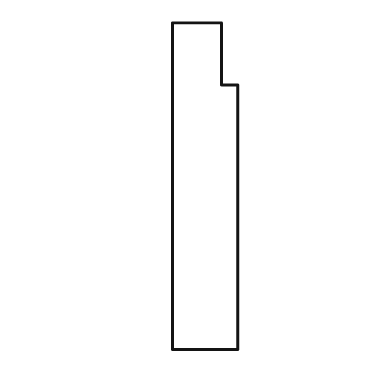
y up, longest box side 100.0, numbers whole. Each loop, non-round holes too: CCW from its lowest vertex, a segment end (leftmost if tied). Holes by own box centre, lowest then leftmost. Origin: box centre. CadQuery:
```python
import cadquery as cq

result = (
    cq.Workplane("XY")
    .moveTo(-10.0, -50.0)
    .lineTo(10.0, -50.0)
    .lineTo(10.0, 31.0)
    .lineTo(5.0, 31.0)
    .lineTo(5.0, 50.0)
    .lineTo(-10.0, 50.0)
    .close()
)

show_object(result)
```